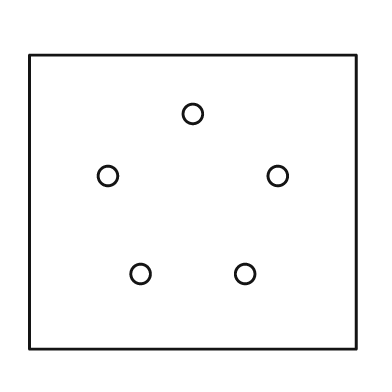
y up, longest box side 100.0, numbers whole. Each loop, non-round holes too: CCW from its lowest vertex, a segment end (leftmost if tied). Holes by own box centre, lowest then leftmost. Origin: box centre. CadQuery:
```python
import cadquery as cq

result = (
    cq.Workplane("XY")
    .moveTo(-50.0, -45.0)
    .lineTo(50.0, -45.0)
    .lineTo(50.0, 45.0)
    .lineTo(-50.0, 45.0)
    .close()
    .moveTo(-16.0, -22.0)
    .circle(3.0)
    .moveTo(16.0, -22.0)
    .circle(3.0)
    .moveTo(-26.0, 8.0)
    .circle(3.0)
    .moveTo(26.0, 8.0)
    .circle(3.0)
    .moveTo(0.0, 27.0)
    .circle(3.0)
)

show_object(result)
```